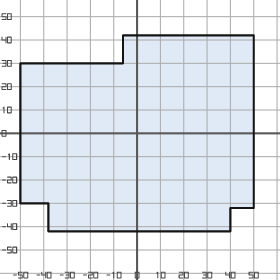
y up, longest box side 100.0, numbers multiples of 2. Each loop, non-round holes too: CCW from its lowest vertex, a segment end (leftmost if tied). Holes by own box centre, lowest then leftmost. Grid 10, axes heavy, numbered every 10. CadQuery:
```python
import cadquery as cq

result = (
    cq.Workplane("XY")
    .moveTo(-38.0, -42.0)
    .lineTo(40.0, -42.0)
    .lineTo(40.0, -32.0)
    .lineTo(50.0, -32.0)
    .lineTo(50.0, 42.0)
    .lineTo(-6.0, 42.0)
    .lineTo(-6.0, 30.0)
    .lineTo(-50.0, 30.0)
    .lineTo(-50.0, -30.0)
    .lineTo(-38.0, -30.0)
    .close()
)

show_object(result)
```